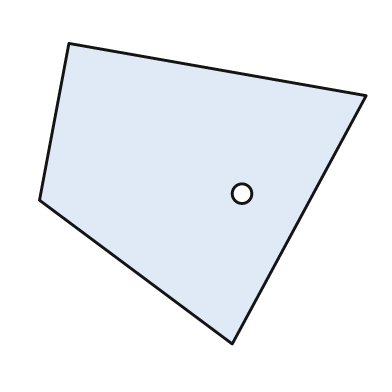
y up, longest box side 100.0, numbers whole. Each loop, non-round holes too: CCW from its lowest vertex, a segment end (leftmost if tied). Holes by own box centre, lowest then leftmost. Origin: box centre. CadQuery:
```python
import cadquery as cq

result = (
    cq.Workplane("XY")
    .moveTo(9.0, -46.0)
    .lineTo(50.0, 30.0)
    .lineTo(-41.0, 46.0)
    .lineTo(-50.0, -2.0)
    .close()
    .moveTo(12.0, 0.0)
    .circle(3.0)
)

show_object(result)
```